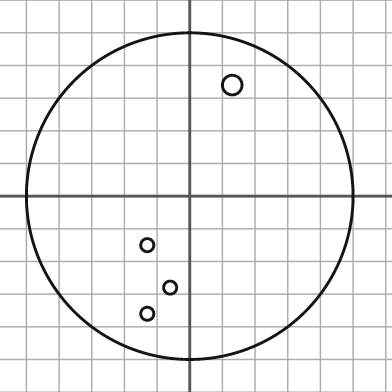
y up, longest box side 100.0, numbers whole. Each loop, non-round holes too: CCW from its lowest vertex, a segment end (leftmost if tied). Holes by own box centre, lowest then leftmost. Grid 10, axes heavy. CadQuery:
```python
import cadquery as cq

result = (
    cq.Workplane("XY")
    .moveTo(0.0, 0.0)
    .circle(50.0)
    .moveTo(-13.0, -36.0)
    .circle(2.0)
    .moveTo(-6.0, -28.0)
    .circle(2.0)
    .moveTo(-13.0, -15.0)
    .circle(2.0)
    .moveTo(13.0, 34.0)
    .circle(3.0)
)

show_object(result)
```